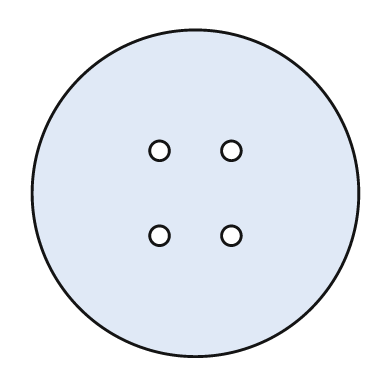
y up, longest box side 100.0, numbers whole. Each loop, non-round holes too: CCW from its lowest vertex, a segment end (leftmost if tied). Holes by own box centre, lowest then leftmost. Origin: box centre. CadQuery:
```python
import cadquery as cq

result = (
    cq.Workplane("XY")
    .moveTo(0.0, 0.0)
    .circle(50.0)
    .moveTo(-11.0, -13.0)
    .circle(3.0)
    .moveTo(11.0, -13.0)
    .circle(3.0)
    .moveTo(-11.0, 13.0)
    .circle(3.0)
    .moveTo(11.0, 13.0)
    .circle(3.0)
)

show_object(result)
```